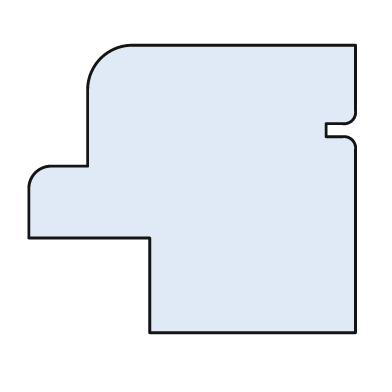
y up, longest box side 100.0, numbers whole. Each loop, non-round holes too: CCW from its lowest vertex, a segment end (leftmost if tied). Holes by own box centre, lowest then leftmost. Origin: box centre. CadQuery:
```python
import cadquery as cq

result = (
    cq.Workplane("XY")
    .moveTo(-13.0, -44.0)
    .lineTo(50.0, -44.0)
    .lineTo(50.0, 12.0)
    .threePointArc((49.0, 15.0), (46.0, 16.0))
    .lineTo(41.0, 16.0)
    .lineTo(41.0, 20.0)
    .lineTo(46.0, 20.0)
    .threePointArc((49.0, 21.0), (50.0, 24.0))
    .lineTo(50.0, 44.0)
    .lineTo(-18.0, 44.0)
    .threePointArc((-28.0, 40.0), (-32.0, 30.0))
    .lineTo(-32.0, 7.0)
    .lineTo(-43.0, 7.0)
    .threePointArc((-48.0, 5.0), (-50.0, 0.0))
    .lineTo(-50.0, -15.0)
    .lineTo(-13.0, -15.0)
    .close()
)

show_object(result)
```